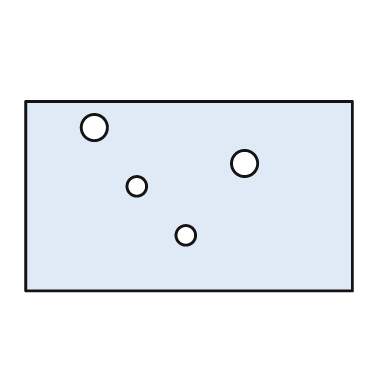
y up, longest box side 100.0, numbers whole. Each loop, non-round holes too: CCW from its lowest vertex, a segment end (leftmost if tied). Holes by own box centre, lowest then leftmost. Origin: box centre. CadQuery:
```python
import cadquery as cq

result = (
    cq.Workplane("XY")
    .moveTo(-50.0, -29.0)
    .lineTo(50.0, -29.0)
    .lineTo(50.0, 29.0)
    .lineTo(-50.0, 29.0)
    .close()
    .moveTo(-1.0, -12.0)
    .circle(3.0)
    .moveTo(-16.0, 3.0)
    .circle(3.0)
    .moveTo(17.0, 10.0)
    .circle(4.0)
    .moveTo(-29.0, 21.0)
    .circle(4.0)
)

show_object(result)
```